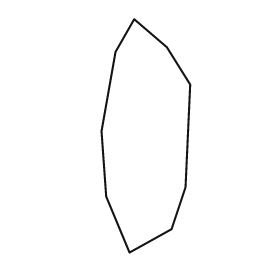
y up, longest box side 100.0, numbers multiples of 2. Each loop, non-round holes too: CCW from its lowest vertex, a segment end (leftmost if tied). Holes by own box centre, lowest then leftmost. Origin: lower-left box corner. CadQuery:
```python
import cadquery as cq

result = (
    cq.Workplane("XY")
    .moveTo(12.0, 0.0)
    .lineTo(30.0, 10.0)
    .lineTo(36.0, 28.0)
    .lineTo(38.0, 72.0)
    .lineTo(28.0, 88.0)
    .lineTo(14.0, 100.0)
    .lineTo(6.0, 86.0)
    .lineTo(0.0, 52.0)
    .lineTo(2.0, 24.0)
    .close()
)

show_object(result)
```